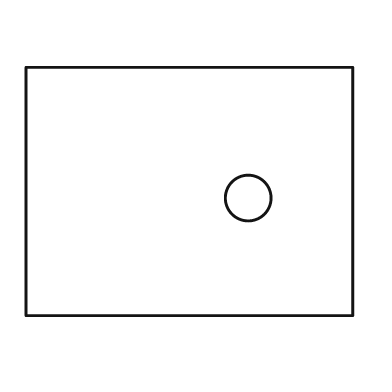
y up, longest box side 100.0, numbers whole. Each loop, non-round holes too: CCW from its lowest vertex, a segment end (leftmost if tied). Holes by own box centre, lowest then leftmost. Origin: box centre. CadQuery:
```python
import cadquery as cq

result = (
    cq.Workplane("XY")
    .moveTo(-50.0, -38.0)
    .lineTo(50.0, -38.0)
    .lineTo(50.0, 38.0)
    .lineTo(-50.0, 38.0)
    .close()
    .moveTo(18.0, -2.0)
    .circle(7.0)
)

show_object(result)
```